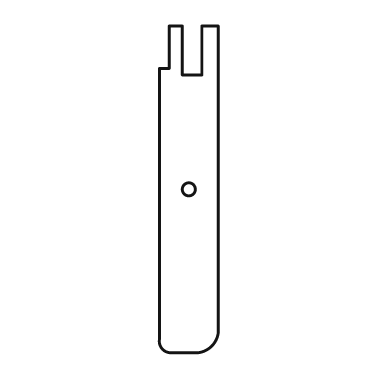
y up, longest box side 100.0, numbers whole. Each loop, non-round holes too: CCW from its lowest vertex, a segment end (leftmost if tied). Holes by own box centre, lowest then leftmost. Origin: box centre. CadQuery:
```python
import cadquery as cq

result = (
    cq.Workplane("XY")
    .moveTo(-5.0, -50.0)
    .lineTo(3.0, -50.0)
    .threePointArc((7.0, -48.0), (9.0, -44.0))
    .lineTo(9.0, 50.0)
    .lineTo(4.0, 50.0)
    .lineTo(4.0, 35.0)
    .lineTo(-2.0, 35.0)
    .lineTo(-2.0, 50.0)
    .lineTo(-6.0, 50.0)
    .lineTo(-6.0, 37.0)
    .lineTo(-9.0, 37.0)
    .lineTo(-9.0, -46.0)
    .threePointArc((-8.0, -49.0), (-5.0, -50.0))
    .close()
    .moveTo(0.0, 0.0)
    .circle(2.0)
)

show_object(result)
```